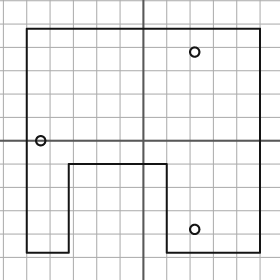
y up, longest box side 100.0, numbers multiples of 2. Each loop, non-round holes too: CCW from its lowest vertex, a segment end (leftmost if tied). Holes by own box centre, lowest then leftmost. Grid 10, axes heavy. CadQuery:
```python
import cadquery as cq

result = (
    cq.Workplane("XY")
    .moveTo(-50.0, -48.0)
    .lineTo(-32.0, -48.0)
    .lineTo(-32.0, -10.0)
    .lineTo(10.0, -10.0)
    .lineTo(10.0, -48.0)
    .lineTo(50.0, -48.0)
    .lineTo(50.0, 48.0)
    .lineTo(-50.0, 48.0)
    .close()
    .moveTo(22.0, -38.0)
    .circle(2.0)
    .moveTo(-44.0, 0.0)
    .circle(2.0)
    .moveTo(22.0, 38.0)
    .circle(2.0)
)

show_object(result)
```